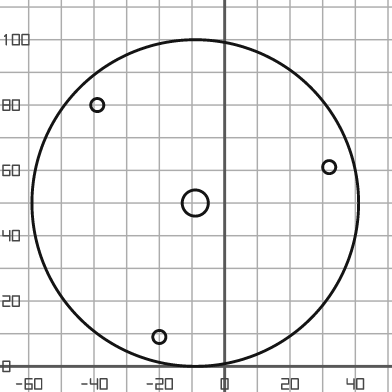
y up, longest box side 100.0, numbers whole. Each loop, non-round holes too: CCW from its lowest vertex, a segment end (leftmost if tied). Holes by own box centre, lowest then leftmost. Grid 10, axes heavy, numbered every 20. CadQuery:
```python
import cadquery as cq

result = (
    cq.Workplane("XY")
    .moveTo(-9.0, 50.0)
    .circle(50.0)
    .moveTo(-20.0, 9.0)
    .circle(2.0)
    .moveTo(-9.0, 50.0)
    .circle(4.0)
    .moveTo(32.0, 61.0)
    .circle(2.0)
    .moveTo(-39.0, 80.0)
    .circle(2.0)
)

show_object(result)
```